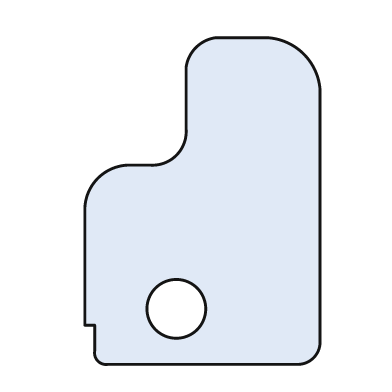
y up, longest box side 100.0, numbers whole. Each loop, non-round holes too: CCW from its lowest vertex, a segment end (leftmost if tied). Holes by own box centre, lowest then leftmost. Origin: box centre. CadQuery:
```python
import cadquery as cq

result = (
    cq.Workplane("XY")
    .moveTo(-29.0, -50.0)
    .lineTo(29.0, -50.0)
    .threePointArc((34.0, -48.0), (36.0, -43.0))
    .lineTo(36.0, 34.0)
    .threePointArc((31.0, 45.0), (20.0, 50.0))
    .lineTo(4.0, 50.0)
    .threePointArc((-2.0, 47.0), (-5.0, 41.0))
    .lineTo(-5.0, 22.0)
    .threePointArc((-8.0, 14.0), (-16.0, 11.0))
    .lineTo(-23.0, 11.0)
    .threePointArc((-32.0, 7.0), (-36.0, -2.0))
    .lineTo(-36.0, -38.0)
    .lineTo(-33.0, -38.0)
    .lineTo(-33.0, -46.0)
    .threePointArc((-32.0, -49.0), (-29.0, -50.0))
    .close()
    .moveTo(-8.0, -33.0)
    .circle(9.0)
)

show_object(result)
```